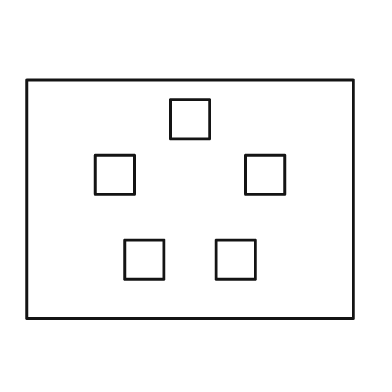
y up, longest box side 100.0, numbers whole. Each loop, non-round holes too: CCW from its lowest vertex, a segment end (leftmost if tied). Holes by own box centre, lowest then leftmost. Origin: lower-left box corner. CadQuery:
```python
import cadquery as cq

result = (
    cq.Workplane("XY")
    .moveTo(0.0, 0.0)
    .lineTo(100.0, 0.0)
    .lineTo(100.0, 73.0)
    .lineTo(0.0, 73.0)
    .close()
    .moveTo(30.0, 12.0)
    .lineTo(42.0, 12.0)
    .lineTo(42.0, 24.0)
    .lineTo(30.0, 24.0)
    .close()
    .moveTo(58.0, 12.0)
    .lineTo(70.0, 12.0)
    .lineTo(70.0, 24.0)
    .lineTo(58.0, 24.0)
    .close()
    .moveTo(21.0, 38.0)
    .lineTo(33.0, 38.0)
    .lineTo(33.0, 50.0)
    .lineTo(21.0, 50.0)
    .close()
    .moveTo(67.0, 38.0)
    .lineTo(79.0, 38.0)
    .lineTo(79.0, 50.0)
    .lineTo(67.0, 50.0)
    .close()
    .moveTo(44.0, 55.0)
    .lineTo(56.0, 55.0)
    .lineTo(56.0, 67.0)
    .lineTo(44.0, 67.0)
    .close()
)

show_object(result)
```